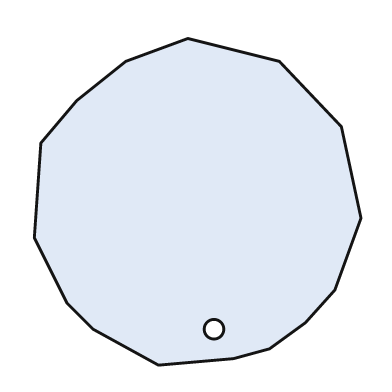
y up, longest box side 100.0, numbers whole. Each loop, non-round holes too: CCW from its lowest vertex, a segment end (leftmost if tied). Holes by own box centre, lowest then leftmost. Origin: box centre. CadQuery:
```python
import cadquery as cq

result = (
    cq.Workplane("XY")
    .moveTo(-12.0, -50.0)
    .lineTo(11.0, -48.0)
    .lineTo(22.0, -45.0)
    .lineTo(33.0, -37.0)
    .lineTo(42.0, -27.0)
    .lineTo(50.0, -5.0)
    .lineTo(44.0, 23.0)
    .lineTo(25.0, 43.0)
    .lineTo(-3.0, 50.0)
    .lineTo(-22.0, 43.0)
    .lineTo(-37.0, 31.0)
    .lineTo(-48.0, 18.0)
    .lineTo(-50.0, -11.0)
    .lineTo(-40.0, -31.0)
    .lineTo(-32.0, -39.0)
    .close()
    .moveTo(5.0, -39.0)
    .circle(3.0)
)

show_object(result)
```